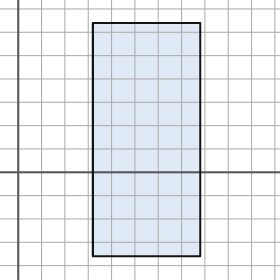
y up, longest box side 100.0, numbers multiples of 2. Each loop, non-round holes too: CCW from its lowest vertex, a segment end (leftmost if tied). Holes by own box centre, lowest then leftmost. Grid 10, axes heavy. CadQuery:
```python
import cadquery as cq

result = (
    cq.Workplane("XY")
    .moveTo(32.0, -36.0)
    .lineTo(78.0, -36.0)
    .lineTo(78.0, 64.0)
    .lineTo(32.0, 64.0)
    .close()
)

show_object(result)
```